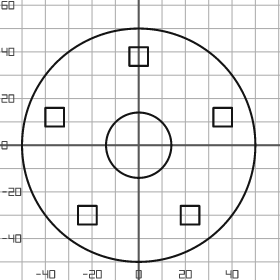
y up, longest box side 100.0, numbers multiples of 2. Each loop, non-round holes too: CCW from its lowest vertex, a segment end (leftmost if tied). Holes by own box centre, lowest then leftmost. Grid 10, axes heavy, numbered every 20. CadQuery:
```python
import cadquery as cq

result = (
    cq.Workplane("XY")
    .moveTo(0.0, 0.0)
    .circle(50.0)
    .moveTo(-26.0, -34.0)
    .lineTo(-18.0, -34.0)
    .lineTo(-18.0, -26.0)
    .lineTo(-26.0, -26.0)
    .close()
    .moveTo(18.0, -34.0)
    .lineTo(26.0, -34.0)
    .lineTo(26.0, -26.0)
    .lineTo(18.0, -26.0)
    .close()
    .moveTo(0.0, 0.0)
    .circle(14.0)
    .moveTo(-40.0, 8.0)
    .lineTo(-32.0, 8.0)
    .lineTo(-32.0, 16.0)
    .lineTo(-40.0, 16.0)
    .close()
    .moveTo(32.0, 8.0)
    .lineTo(40.0, 8.0)
    .lineTo(40.0, 16.0)
    .lineTo(32.0, 16.0)
    .close()
    .moveTo(-4.0, 34.0)
    .lineTo(4.0, 34.0)
    .lineTo(4.0, 42.0)
    .lineTo(-4.0, 42.0)
    .close()
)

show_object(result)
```